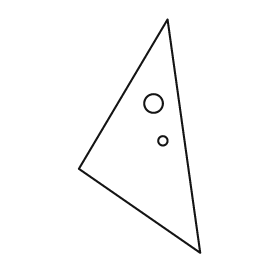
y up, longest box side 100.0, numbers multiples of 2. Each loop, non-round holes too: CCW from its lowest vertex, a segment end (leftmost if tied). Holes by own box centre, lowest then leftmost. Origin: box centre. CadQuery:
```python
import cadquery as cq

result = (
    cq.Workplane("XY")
    .moveTo(26.0, -50.0)
    .lineTo(12.0, 50.0)
    .lineTo(-26.0, -14.0)
    .close()
    .moveTo(10.0, -2.0)
    .circle(2.0)
    .moveTo(6.0, 14.0)
    .circle(4.0)
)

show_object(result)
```